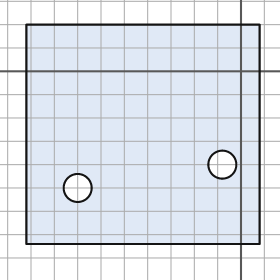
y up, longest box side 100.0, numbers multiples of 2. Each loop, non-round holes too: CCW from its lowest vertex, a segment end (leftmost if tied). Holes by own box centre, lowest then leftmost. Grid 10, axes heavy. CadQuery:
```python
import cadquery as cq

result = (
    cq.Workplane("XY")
    .moveTo(-92.0, -74.0)
    .lineTo(8.0, -74.0)
    .lineTo(8.0, 20.0)
    .lineTo(-92.0, 20.0)
    .close()
    .moveTo(-70.0, -50.0)
    .circle(6.0)
    .moveTo(-8.0, -40.0)
    .circle(6.0)
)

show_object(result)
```